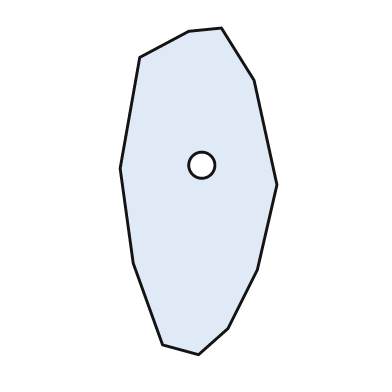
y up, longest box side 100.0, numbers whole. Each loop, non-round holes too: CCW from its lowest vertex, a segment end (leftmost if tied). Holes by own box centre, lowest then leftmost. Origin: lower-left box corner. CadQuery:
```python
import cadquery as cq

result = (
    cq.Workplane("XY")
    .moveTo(24.0, 0.0)
    .lineTo(33.0, 8.0)
    .lineTo(42.0, 26.0)
    .lineTo(48.0, 52.0)
    .lineTo(41.0, 84.0)
    .lineTo(31.0, 100.0)
    .lineTo(21.0, 99.0)
    .lineTo(6.0, 91.0)
    .lineTo(0.0, 57.0)
    .lineTo(4.0, 28.0)
    .lineTo(13.0, 3.0)
    .close()
    .moveTo(25.0, 58.0)
    .circle(4.0)
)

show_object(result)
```